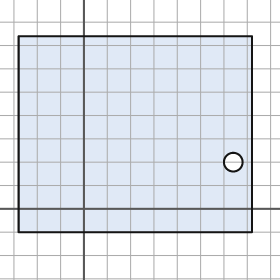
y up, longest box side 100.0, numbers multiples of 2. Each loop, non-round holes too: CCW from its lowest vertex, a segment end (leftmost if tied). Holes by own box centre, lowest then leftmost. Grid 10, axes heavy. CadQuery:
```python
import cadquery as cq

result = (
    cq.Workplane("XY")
    .moveTo(-28.0, -10.0)
    .lineTo(72.0, -10.0)
    .lineTo(72.0, 74.0)
    .lineTo(-28.0, 74.0)
    .close()
    .moveTo(64.0, 20.0)
    .circle(4.0)
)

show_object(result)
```